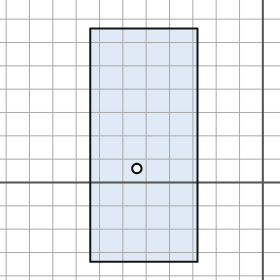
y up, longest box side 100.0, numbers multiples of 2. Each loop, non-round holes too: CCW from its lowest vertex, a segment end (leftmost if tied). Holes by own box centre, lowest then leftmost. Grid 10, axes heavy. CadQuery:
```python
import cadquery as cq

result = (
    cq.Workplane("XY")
    .moveTo(-74.0, -34.0)
    .lineTo(-28.0, -34.0)
    .lineTo(-28.0, 66.0)
    .lineTo(-74.0, 66.0)
    .close()
    .moveTo(-54.0, 6.0)
    .circle(2.0)
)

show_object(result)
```